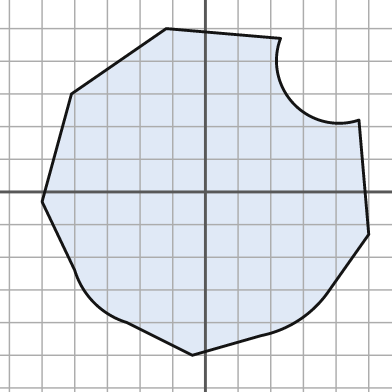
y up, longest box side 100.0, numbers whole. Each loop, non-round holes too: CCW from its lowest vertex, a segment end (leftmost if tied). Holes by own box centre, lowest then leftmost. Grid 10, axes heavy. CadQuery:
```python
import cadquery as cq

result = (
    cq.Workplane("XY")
    .moveTo(-4.0, -50.0)
    .lineTo(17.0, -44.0)
    .threePointArc((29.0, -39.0), (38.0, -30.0))
    .lineTo(50.0, -13.0)
    .lineTo(47.0, 22.0)
    .threePointArc((27.0, 27.0), (23.0, 47.0))
    .lineTo(-12.0, 50.0)
    .lineTo(-41.0, 30.0)
    .lineTo(-50.0, -3.0)
    .lineTo(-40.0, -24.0)
    .threePointArc((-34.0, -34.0), (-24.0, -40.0))
    .close()
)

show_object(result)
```